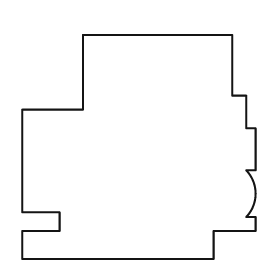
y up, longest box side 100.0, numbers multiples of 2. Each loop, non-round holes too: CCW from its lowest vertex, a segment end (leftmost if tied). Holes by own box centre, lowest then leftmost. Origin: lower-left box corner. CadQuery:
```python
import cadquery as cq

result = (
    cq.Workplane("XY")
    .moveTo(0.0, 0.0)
    .lineTo(82.0, 0.0)
    .lineTo(82.0, 12.0)
    .lineTo(100.0, 12.0)
    .lineTo(100.0, 18.0)
    .lineTo(96.0, 18.0)
    .threePointArc((100.0, 28.0), (96.0, 38.0))
    .lineTo(100.0, 38.0)
    .lineTo(100.0, 56.0)
    .lineTo(96.0, 56.0)
    .lineTo(96.0, 70.0)
    .lineTo(90.0, 70.0)
    .lineTo(90.0, 96.0)
    .lineTo(26.0, 96.0)
    .lineTo(26.0, 64.0)
    .lineTo(0.0, 64.0)
    .lineTo(0.0, 20.0)
    .lineTo(16.0, 20.0)
    .lineTo(16.0, 12.0)
    .lineTo(0.0, 12.0)
    .close()
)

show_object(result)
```